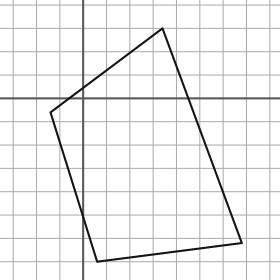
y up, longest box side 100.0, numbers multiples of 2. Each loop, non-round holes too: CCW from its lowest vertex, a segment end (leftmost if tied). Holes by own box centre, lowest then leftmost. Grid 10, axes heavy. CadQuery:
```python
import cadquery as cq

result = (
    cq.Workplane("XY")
    .moveTo(6.0, -70.0)
    .lineTo(68.0, -62.0)
    .lineTo(34.0, 30.0)
    .lineTo(-14.0, -6.0)
    .close()
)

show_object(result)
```